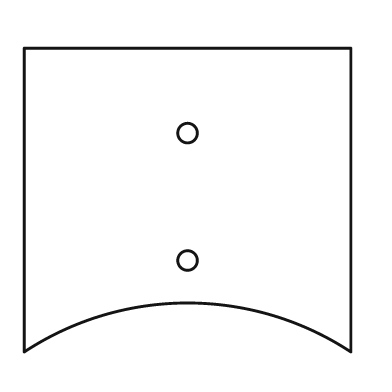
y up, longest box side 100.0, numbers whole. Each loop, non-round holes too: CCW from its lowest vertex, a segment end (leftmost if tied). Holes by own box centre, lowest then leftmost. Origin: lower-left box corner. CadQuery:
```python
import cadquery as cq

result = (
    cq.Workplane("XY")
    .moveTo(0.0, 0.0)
    .threePointArc((50.0, 15.0), (100.0, 0.0))
    .lineTo(100.0, 93.0)
    .lineTo(0.0, 93.0)
    .close()
    .moveTo(50.0, 28.0)
    .circle(3.0)
    .moveTo(50.0, 67.0)
    .circle(3.0)
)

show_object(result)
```